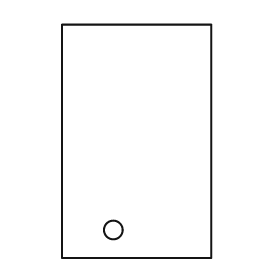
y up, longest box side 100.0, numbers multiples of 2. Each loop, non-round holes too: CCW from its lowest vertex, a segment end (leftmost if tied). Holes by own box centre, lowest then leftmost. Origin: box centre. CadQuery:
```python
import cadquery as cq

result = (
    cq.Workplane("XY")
    .moveTo(-32.0, -50.0)
    .lineTo(32.0, -50.0)
    .lineTo(32.0, 50.0)
    .lineTo(-32.0, 50.0)
    .close()
    .moveTo(-10.0, -38.0)
    .circle(4.0)
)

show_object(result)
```